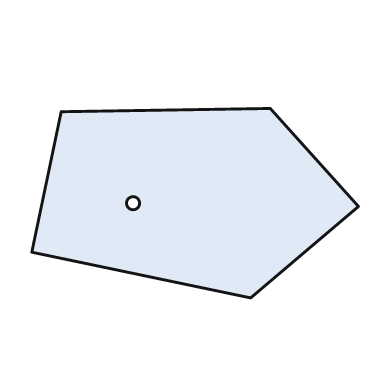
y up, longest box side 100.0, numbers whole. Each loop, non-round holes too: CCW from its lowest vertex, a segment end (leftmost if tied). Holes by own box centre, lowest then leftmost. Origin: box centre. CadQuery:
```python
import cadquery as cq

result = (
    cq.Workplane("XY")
    .moveTo(17.0, -29.0)
    .lineTo(50.0, -1.0)
    .lineTo(23.0, 29.0)
    .lineTo(-41.0, 28.0)
    .lineTo(-50.0, -15.0)
    .close()
    .moveTo(-19.0, 0.0)
    .circle(2.0)
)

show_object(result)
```